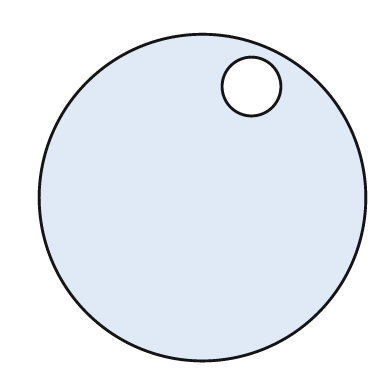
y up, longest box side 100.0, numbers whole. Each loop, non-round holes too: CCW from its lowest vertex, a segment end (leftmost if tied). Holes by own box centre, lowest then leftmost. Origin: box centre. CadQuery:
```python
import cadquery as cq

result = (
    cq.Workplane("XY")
    .moveTo(0.0, 0.0)
    .circle(50.0)
    .moveTo(15.0, 34.0)
    .circle(9.0)
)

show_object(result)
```